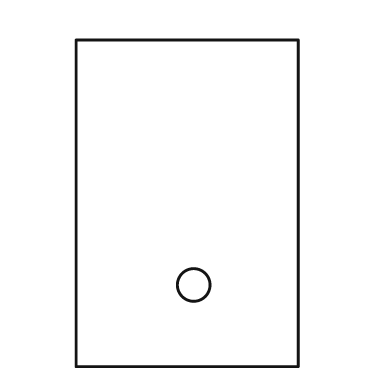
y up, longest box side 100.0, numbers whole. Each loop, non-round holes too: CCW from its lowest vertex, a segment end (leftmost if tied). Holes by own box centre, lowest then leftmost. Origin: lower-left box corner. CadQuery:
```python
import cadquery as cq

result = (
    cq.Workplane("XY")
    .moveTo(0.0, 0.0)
    .lineTo(68.0, 0.0)
    .lineTo(68.0, 100.0)
    .lineTo(0.0, 100.0)
    .close()
    .moveTo(36.0, 25.0)
    .circle(5.0)
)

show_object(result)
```